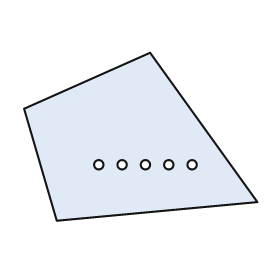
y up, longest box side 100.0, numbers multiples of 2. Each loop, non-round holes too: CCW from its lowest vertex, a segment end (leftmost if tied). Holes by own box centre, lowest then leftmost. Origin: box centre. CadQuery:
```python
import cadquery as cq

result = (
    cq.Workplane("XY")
    .moveTo(-36.0, -36.0)
    .lineTo(50.0, -28.0)
    .lineTo(4.0, 36.0)
    .lineTo(-50.0, 12.0)
    .close()
    .moveTo(-18.0, -12.0)
    .circle(2.0)
    .moveTo(-8.0, -12.0)
    .circle(2.0)
    .moveTo(2.0, -12.0)
    .circle(2.0)
    .moveTo(12.0, -12.0)
    .circle(2.0)
    .moveTo(22.0, -12.0)
    .circle(2.0)
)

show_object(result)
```